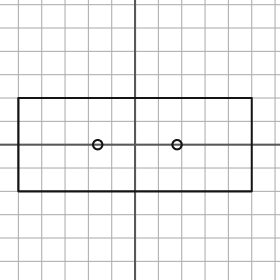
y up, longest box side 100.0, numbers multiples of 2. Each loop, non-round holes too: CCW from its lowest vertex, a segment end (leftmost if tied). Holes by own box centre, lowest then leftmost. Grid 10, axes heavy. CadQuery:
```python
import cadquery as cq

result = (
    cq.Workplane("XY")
    .moveTo(-50.0, -20.0)
    .lineTo(50.0, -20.0)
    .lineTo(50.0, 20.0)
    .lineTo(-50.0, 20.0)
    .close()
    .moveTo(-16.0, 0.0)
    .circle(2.0)
    .moveTo(18.0, 0.0)
    .circle(2.0)
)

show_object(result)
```